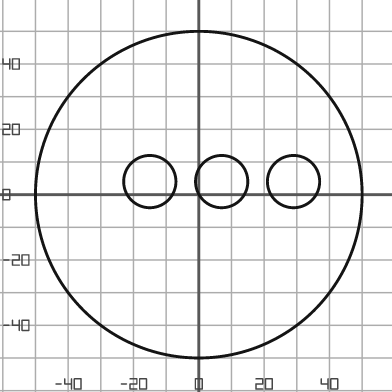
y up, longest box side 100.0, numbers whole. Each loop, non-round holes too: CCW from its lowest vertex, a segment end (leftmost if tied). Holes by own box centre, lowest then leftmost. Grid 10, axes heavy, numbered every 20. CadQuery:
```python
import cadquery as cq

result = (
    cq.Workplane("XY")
    .moveTo(0.0, 0.0)
    .circle(50.0)
    .moveTo(-15.0, 4.0)
    .circle(8.0)
    .moveTo(7.0, 4.0)
    .circle(8.0)
    .moveTo(29.0, 4.0)
    .circle(8.0)
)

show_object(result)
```